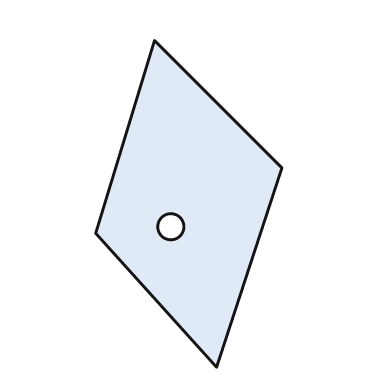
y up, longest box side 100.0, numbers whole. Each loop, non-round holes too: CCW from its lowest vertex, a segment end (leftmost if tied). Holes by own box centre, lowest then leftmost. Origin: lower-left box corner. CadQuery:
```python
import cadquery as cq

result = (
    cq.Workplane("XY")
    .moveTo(37.0, 0.0)
    .lineTo(57.0, 61.0)
    .lineTo(18.0, 100.0)
    .lineTo(0.0, 41.0)
    .close()
    .moveTo(23.0, 43.0)
    .circle(4.0)
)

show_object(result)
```